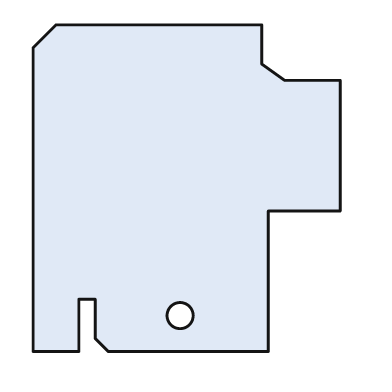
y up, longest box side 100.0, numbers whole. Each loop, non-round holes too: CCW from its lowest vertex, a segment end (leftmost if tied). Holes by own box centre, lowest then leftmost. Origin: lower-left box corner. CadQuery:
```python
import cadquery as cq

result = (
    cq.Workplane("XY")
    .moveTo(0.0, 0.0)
    .lineTo(14.0, 0.0)
    .lineTo(14.0, 16.0)
    .lineTo(19.0, 16.0)
    .lineTo(19.0, 4.0)
    .lineTo(23.0, 0.0)
    .lineTo(72.0, 0.0)
    .lineTo(72.0, 43.0)
    .lineTo(94.0, 43.0)
    .lineTo(94.0, 83.0)
    .lineTo(77.0, 83.0)
    .lineTo(70.0, 88.0)
    .lineTo(70.0, 100.0)
    .lineTo(7.0, 100.0)
    .lineTo(0.0, 93.0)
    .close()
    .moveTo(45.0, 11.0)
    .circle(4.0)
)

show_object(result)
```